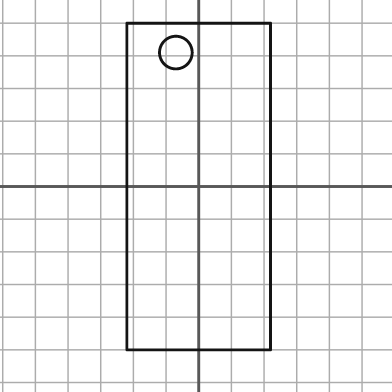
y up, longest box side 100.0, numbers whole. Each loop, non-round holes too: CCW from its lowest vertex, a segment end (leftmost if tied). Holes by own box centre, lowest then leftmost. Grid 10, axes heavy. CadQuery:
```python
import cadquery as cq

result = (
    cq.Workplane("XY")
    .moveTo(-22.0, -50.0)
    .lineTo(22.0, -50.0)
    .lineTo(22.0, 50.0)
    .lineTo(-22.0, 50.0)
    .close()
    .moveTo(-7.0, 41.0)
    .circle(5.0)
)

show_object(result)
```